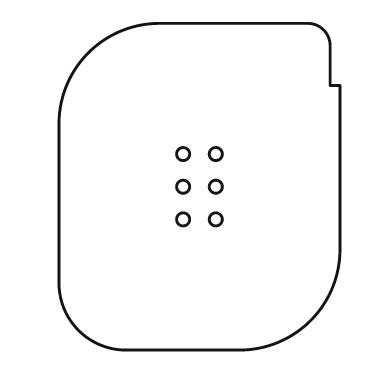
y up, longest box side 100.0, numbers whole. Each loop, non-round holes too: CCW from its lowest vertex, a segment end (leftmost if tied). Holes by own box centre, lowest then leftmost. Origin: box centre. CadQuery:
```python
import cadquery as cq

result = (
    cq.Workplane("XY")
    .moveTo(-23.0, -50.0)
    .lineTo(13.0, -50.0)
    .threePointArc((34.0, -41.0), (43.0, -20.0))
    .lineTo(43.0, 31.0)
    .lineTo(40.0, 31.0)
    .lineTo(40.0, 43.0)
    .threePointArc((38.0, 48.0), (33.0, 50.0))
    .lineTo(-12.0, 50.0)
    .threePointArc((-34.0, 41.0), (-43.0, 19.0))
    .lineTo(-43.0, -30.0)
    .threePointArc((-37.0, -44.0), (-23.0, -50.0))
    .close()
    .moveTo(-5.0, -10.0)
    .circle(2.0)
    .moveTo(5.0, -10.0)
    .circle(2.0)
    .moveTo(-5.0, 0.0)
    .circle(2.0)
    .moveTo(5.0, 0.0)
    .circle(2.0)
    .moveTo(-5.0, 10.0)
    .circle(2.0)
    .moveTo(5.0, 10.0)
    .circle(2.0)
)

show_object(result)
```